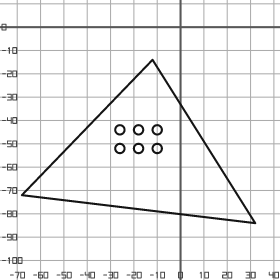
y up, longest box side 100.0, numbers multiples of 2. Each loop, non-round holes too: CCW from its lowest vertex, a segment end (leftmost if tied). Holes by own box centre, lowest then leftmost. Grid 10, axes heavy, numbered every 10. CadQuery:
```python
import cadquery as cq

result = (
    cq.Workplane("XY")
    .moveTo(32.0, -84.0)
    .lineTo(-12.0, -14.0)
    .lineTo(-68.0, -72.0)
    .close()
    .moveTo(-26.0, -52.0)
    .circle(2.0)
    .moveTo(-18.0, -52.0)
    .circle(2.0)
    .moveTo(-10.0, -52.0)
    .circle(2.0)
    .moveTo(-26.0, -44.0)
    .circle(2.0)
    .moveTo(-18.0, -44.0)
    .circle(2.0)
    .moveTo(-10.0, -44.0)
    .circle(2.0)
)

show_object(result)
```